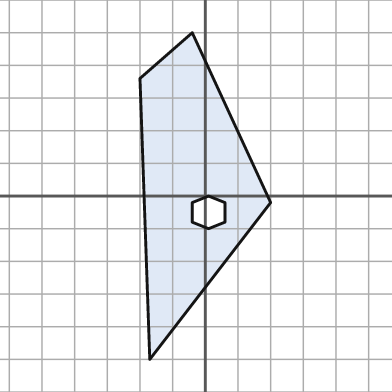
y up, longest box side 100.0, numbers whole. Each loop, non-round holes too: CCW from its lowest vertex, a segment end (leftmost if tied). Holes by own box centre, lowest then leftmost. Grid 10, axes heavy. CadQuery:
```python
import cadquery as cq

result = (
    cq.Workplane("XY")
    .moveTo(-17.0, -50.0)
    .lineTo(20.0, -2.0)
    .lineTo(-4.0, 50.0)
    .lineTo(-20.0, 36.0)
    .close()
    .moveTo(1.0, -10.0)
    .lineTo(6.0, -8.0)
    .lineTo(6.0, -2.0)
    .lineTo(1.0, 0.0)
    .lineTo(-4.0, -2.0)
    .lineTo(-4.0, -8.0)
    .close()
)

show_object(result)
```